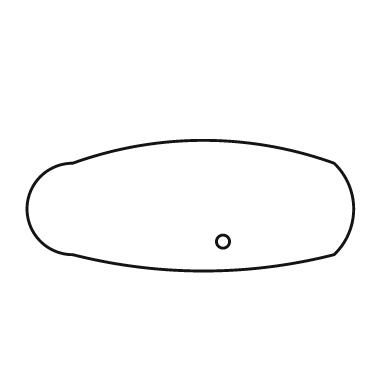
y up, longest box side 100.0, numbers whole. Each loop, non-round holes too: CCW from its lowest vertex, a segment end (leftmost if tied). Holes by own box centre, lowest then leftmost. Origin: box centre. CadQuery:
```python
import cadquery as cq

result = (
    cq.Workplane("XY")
    .moveTo(-36.0, -15.0)
    .threePointArc((4.0, -20.0), (44.0, -15.0))
    .threePointArc((50.0, -1.0), (44.0, 13.0))
    .threePointArc((4.0, 20.0), (-36.0, 13.0))
    .threePointArc((-50.0, -1.0), (-36.0, -15.0))
    .close()
    .moveTo(10.0, -11.0)
    .circle(2.0)
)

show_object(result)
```